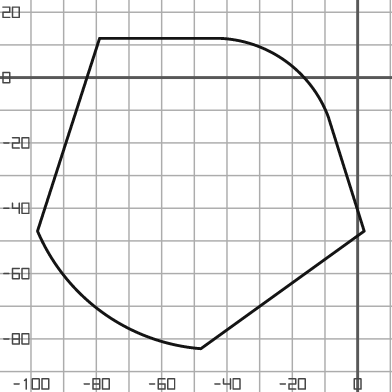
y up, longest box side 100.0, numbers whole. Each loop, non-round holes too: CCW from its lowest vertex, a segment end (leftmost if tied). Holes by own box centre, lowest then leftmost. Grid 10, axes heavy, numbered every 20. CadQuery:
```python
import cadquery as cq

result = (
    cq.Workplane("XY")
    .moveTo(-48.0, -83.0)
    .lineTo(2.0, -47.0)
    .lineTo(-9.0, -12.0)
    .threePointArc((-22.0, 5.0), (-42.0, 12.0))
    .lineTo(-79.0, 12.0)
    .lineTo(-98.0, -47.0)
    .threePointArc((-78.0, -72.0), (-48.0, -83.0))
    .close()
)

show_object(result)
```